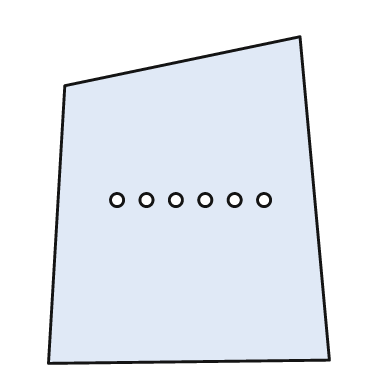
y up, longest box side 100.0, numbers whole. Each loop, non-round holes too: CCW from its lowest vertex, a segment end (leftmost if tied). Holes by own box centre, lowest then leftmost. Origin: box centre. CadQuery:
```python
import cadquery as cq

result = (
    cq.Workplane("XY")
    .moveTo(-43.0, -50.0)
    .lineTo(43.0, -49.0)
    .lineTo(34.0, 50.0)
    .lineTo(-38.0, 35.0)
    .close()
    .moveTo(-22.0, 0.0)
    .circle(2.0)
    .moveTo(-13.0, 0.0)
    .circle(2.0)
    .moveTo(-4.0, 0.0)
    .circle(2.0)
    .moveTo(5.0, 0.0)
    .circle(2.0)
    .moveTo(14.0, 0.0)
    .circle(2.0)
    .moveTo(23.0, 0.0)
    .circle(2.0)
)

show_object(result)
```